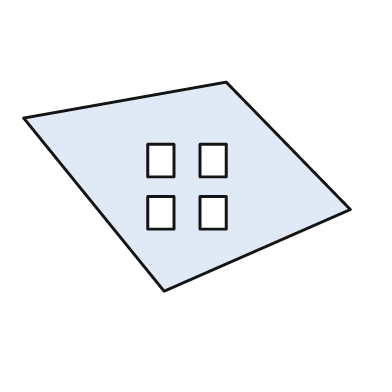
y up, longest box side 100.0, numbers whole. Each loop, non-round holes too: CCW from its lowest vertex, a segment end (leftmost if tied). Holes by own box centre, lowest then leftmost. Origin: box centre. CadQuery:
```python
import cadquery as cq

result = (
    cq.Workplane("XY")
    .moveTo(-7.0, -32.0)
    .lineTo(50.0, -7.0)
    .lineTo(12.0, 32.0)
    .lineTo(-50.0, 21.0)
    .close()
    .moveTo(-12.0, -13.0)
    .lineTo(-4.0, -13.0)
    .lineTo(-4.0, -3.0)
    .lineTo(-12.0, -3.0)
    .close()
    .moveTo(4.0, -13.0)
    .lineTo(12.0, -13.0)
    .lineTo(12.0, -3.0)
    .lineTo(4.0, -3.0)
    .close()
    .moveTo(-12.0, 3.0)
    .lineTo(-4.0, 3.0)
    .lineTo(-4.0, 13.0)
    .lineTo(-12.0, 13.0)
    .close()
    .moveTo(4.0, 3.0)
    .lineTo(12.0, 3.0)
    .lineTo(12.0, 13.0)
    .lineTo(4.0, 13.0)
    .close()
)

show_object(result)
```